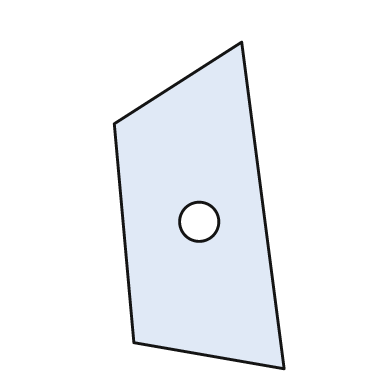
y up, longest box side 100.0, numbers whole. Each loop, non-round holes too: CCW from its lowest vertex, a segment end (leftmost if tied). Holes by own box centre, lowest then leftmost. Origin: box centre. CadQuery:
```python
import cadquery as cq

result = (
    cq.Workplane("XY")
    .moveTo(26.0, -50.0)
    .lineTo(13.0, 50.0)
    .lineTo(-26.0, 25.0)
    .lineTo(-20.0, -42.0)
    .close()
    .moveTo(0.0, -5.0)
    .circle(6.0)
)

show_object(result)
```